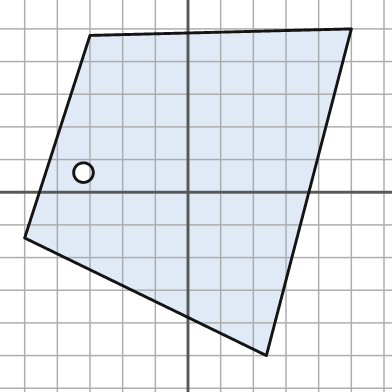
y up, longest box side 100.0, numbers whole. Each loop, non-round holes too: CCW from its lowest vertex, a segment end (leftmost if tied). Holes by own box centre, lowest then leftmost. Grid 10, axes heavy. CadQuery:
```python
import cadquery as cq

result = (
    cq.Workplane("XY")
    .moveTo(24.0, -50.0)
    .lineTo(50.0, 50.0)
    .lineTo(-30.0, 48.0)
    .lineTo(-50.0, -14.0)
    .close()
    .moveTo(-32.0, 6.0)
    .circle(3.0)
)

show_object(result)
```